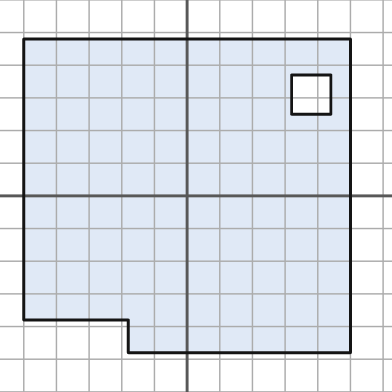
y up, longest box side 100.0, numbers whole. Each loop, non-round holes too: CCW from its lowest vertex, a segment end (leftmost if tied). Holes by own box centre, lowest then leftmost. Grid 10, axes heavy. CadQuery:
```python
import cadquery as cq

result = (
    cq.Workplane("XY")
    .moveTo(-18.0, -48.0)
    .lineTo(50.0, -48.0)
    .lineTo(50.0, 48.0)
    .lineTo(-50.0, 48.0)
    .lineTo(-50.0, -38.0)
    .lineTo(-18.0, -38.0)
    .close()
    .moveTo(32.0, 25.0)
    .lineTo(44.0, 25.0)
    .lineTo(44.0, 37.0)
    .lineTo(32.0, 37.0)
    .close()
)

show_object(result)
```